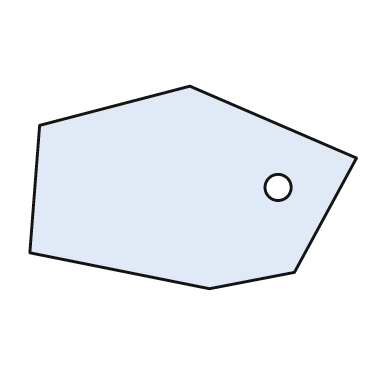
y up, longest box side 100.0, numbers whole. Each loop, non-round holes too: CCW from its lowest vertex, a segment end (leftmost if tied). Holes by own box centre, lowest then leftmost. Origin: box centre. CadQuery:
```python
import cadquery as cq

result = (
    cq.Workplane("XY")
    .moveTo(5.0, -31.0)
    .lineTo(31.0, -26.0)
    .lineTo(50.0, 9.0)
    .lineTo(-1.0, 31.0)
    .lineTo(-47.0, 19.0)
    .lineTo(-50.0, -20.0)
    .close()
    .moveTo(26.0, 0.0)
    .circle(4.0)
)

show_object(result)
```